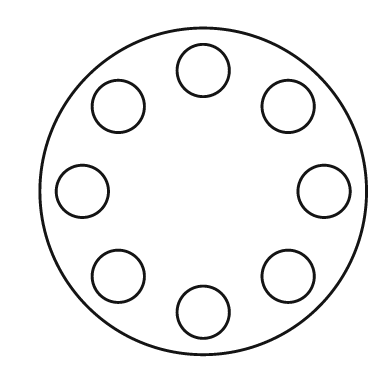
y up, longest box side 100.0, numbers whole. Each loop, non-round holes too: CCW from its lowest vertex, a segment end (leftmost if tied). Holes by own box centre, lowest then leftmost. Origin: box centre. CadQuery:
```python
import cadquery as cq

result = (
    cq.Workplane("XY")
    .moveTo(0.0, 0.0)
    .circle(50.0)
    .moveTo(0.0, -37.0)
    .circle(8.0)
    .moveTo(-26.0, -26.0)
    .circle(8.0)
    .moveTo(26.0, -26.0)
    .circle(8.0)
    .moveTo(-37.0, 0.0)
    .circle(8.0)
    .moveTo(37.0, 0.0)
    .circle(8.0)
    .moveTo(-26.0, 26.0)
    .circle(8.0)
    .moveTo(26.0, 26.0)
    .circle(8.0)
    .moveTo(0.0, 37.0)
    .circle(8.0)
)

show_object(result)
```